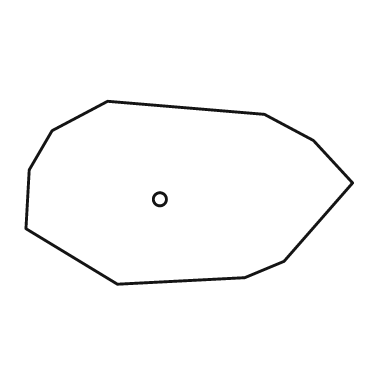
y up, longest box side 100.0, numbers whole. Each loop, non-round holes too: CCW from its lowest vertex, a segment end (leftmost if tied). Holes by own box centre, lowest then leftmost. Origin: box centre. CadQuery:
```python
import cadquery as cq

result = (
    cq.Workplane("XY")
    .moveTo(-22.0, -28.0)
    .lineTo(17.0, -26.0)
    .lineTo(29.0, -21.0)
    .lineTo(50.0, 3.0)
    .lineTo(38.0, 16.0)
    .lineTo(23.0, 24.0)
    .lineTo(-25.0, 28.0)
    .lineTo(-42.0, 19.0)
    .lineTo(-49.0, 7.0)
    .lineTo(-50.0, -11.0)
    .close()
    .moveTo(-9.0, -2.0)
    .circle(2.0)
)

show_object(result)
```